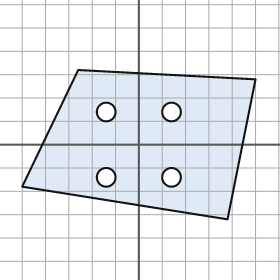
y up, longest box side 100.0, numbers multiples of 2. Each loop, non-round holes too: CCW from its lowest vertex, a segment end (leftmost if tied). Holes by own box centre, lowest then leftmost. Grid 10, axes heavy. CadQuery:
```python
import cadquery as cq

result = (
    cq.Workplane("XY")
    .moveTo(38.0, -32.0)
    .lineTo(50.0, 28.0)
    .lineTo(-26.0, 32.0)
    .lineTo(-50.0, -18.0)
    .close()
    .moveTo(-14.0, -14.0)
    .circle(4.0)
    .moveTo(14.0, -14.0)
    .circle(4.0)
    .moveTo(-14.0, 14.0)
    .circle(4.0)
    .moveTo(14.0, 14.0)
    .circle(4.0)
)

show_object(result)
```